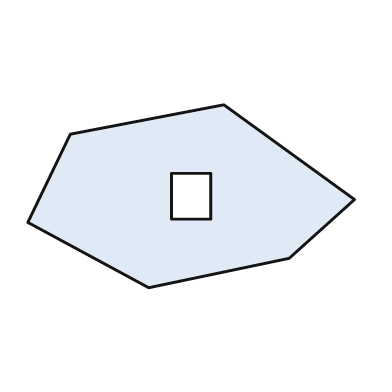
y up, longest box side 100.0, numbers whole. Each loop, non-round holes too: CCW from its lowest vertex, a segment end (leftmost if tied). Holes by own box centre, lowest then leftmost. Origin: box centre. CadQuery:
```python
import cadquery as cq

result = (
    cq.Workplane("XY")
    .moveTo(-13.0, -28.0)
    .lineTo(30.0, -19.0)
    .lineTo(50.0, -1.0)
    .lineTo(10.0, 28.0)
    .lineTo(-37.0, 19.0)
    .lineTo(-50.0, -8.0)
    .close()
    .moveTo(-6.0, -7.0)
    .lineTo(6.0, -7.0)
    .lineTo(6.0, 7.0)
    .lineTo(-6.0, 7.0)
    .close()
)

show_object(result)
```